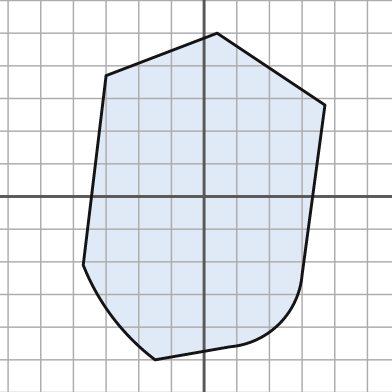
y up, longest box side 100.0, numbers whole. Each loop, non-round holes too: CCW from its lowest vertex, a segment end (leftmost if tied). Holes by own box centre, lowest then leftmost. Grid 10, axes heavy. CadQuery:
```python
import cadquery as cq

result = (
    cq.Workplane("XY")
    .moveTo(-15.0, -50.0)
    .lineTo(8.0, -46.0)
    .threePointArc((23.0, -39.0), (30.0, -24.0))
    .lineTo(37.0, 28.0)
    .lineTo(4.0, 50.0)
    .lineTo(-30.0, 37.0)
    .lineTo(-37.0, -21.0)
    .threePointArc((-28.0, -37.0), (-15.0, -50.0))
    .close()
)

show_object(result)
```